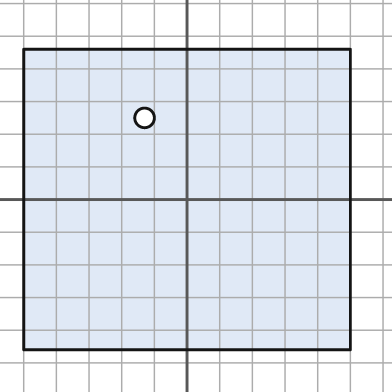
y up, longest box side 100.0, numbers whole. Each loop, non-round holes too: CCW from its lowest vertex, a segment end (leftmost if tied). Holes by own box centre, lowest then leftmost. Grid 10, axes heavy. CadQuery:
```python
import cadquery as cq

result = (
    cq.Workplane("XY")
    .moveTo(-50.0, -46.0)
    .lineTo(50.0, -46.0)
    .lineTo(50.0, 46.0)
    .lineTo(-50.0, 46.0)
    .close()
    .moveTo(-13.0, 25.0)
    .circle(3.0)
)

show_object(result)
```